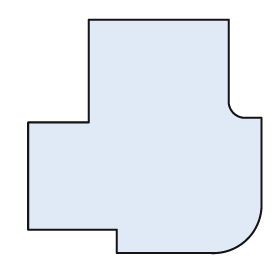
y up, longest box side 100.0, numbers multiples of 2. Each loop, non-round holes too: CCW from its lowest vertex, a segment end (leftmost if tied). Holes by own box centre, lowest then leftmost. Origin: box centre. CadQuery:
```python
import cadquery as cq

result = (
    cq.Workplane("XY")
    .moveTo(-12.0, -50.0)
    .lineTo(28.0, -50.0)
    .threePointArc((44.0, -44.0), (50.0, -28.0))
    .lineTo(50.0, 8.0)
    .lineTo(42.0, 8.0)
    .threePointArc((38.0, 10.0), (36.0, 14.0))
    .lineTo(36.0, 50.0)
    .lineTo(-24.0, 50.0)
    .lineTo(-24.0, 6.0)
    .lineTo(-50.0, 6.0)
    .lineTo(-50.0, -40.0)
    .lineTo(-12.0, -40.0)
    .close()
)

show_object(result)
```